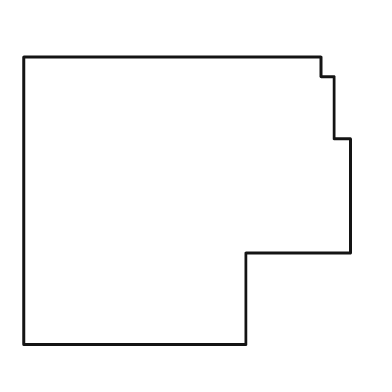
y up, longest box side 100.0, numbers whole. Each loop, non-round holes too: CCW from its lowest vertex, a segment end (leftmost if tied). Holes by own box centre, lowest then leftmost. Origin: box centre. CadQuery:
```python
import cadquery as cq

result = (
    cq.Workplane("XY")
    .moveTo(-50.0, -44.0)
    .lineTo(18.0, -44.0)
    .lineTo(18.0, -16.0)
    .lineTo(50.0, -16.0)
    .lineTo(50.0, 19.0)
    .lineTo(45.0, 19.0)
    .lineTo(45.0, 38.0)
    .lineTo(41.0, 38.0)
    .lineTo(41.0, 44.0)
    .lineTo(-50.0, 44.0)
    .close()
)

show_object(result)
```